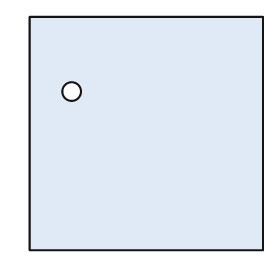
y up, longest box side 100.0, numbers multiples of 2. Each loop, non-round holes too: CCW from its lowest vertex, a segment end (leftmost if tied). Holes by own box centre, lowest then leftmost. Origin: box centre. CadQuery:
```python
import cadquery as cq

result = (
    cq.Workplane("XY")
    .moveTo(-50.0, -50.0)
    .lineTo(50.0, -50.0)
    .lineTo(50.0, 50.0)
    .lineTo(-50.0, 50.0)
    .close()
    .moveTo(-32.0, 18.0)
    .circle(4.0)
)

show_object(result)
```